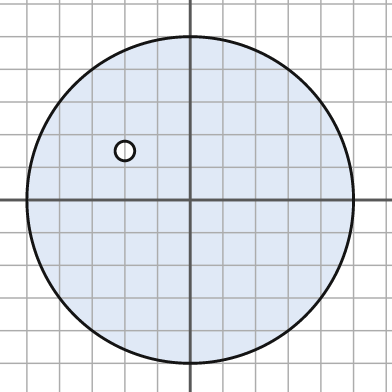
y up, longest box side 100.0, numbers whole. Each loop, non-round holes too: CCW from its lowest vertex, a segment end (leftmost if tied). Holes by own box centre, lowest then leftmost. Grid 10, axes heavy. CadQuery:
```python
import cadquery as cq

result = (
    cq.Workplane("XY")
    .moveTo(0.0, 0.0)
    .circle(50.0)
    .moveTo(-20.0, 15.0)
    .circle(3.0)
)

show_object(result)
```